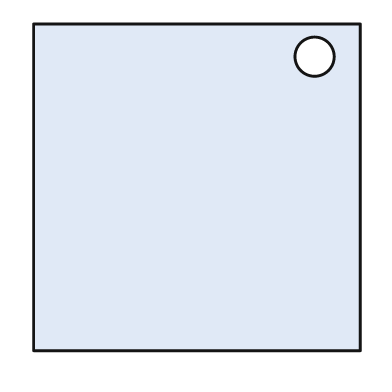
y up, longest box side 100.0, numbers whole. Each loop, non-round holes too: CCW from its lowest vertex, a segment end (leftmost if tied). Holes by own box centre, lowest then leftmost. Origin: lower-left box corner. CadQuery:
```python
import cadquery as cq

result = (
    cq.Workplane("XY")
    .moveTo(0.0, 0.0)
    .lineTo(100.0, 0.0)
    .lineTo(100.0, 100.0)
    .lineTo(0.0, 100.0)
    .close()
    .moveTo(86.0, 90.0)
    .circle(6.0)
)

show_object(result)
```